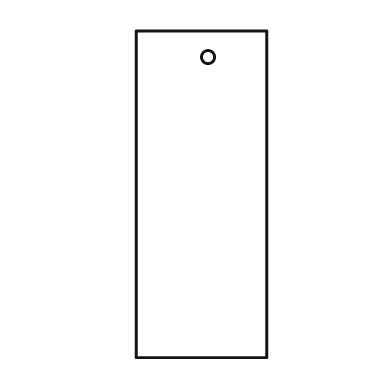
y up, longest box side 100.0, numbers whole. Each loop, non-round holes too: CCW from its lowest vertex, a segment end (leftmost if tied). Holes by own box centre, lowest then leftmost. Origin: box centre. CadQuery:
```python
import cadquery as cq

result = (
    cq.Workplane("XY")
    .moveTo(-20.0, -50.0)
    .lineTo(20.0, -50.0)
    .lineTo(20.0, 50.0)
    .lineTo(-20.0, 50.0)
    .close()
    .moveTo(2.0, 42.0)
    .circle(2.0)
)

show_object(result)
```